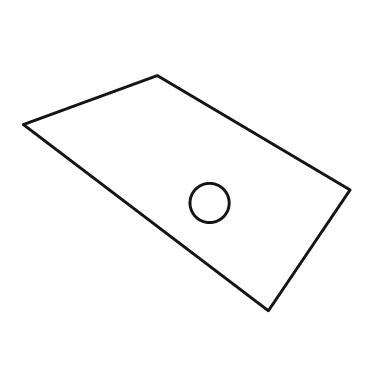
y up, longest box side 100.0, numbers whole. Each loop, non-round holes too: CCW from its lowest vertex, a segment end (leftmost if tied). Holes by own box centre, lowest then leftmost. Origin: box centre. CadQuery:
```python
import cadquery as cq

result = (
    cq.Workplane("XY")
    .moveTo(25.0, -36.0)
    .lineTo(50.0, 1.0)
    .lineTo(-9.0, 36.0)
    .lineTo(-50.0, 21.0)
    .close()
    .moveTo(7.0, -3.0)
    .circle(6.0)
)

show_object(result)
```